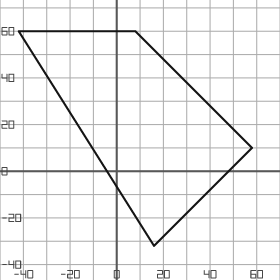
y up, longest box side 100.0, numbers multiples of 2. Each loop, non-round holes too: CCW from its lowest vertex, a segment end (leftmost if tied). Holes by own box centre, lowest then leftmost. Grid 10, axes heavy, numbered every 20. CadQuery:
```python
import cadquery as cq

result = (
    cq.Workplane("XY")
    .moveTo(16.0, -32.0)
    .lineTo(58.0, 10.0)
    .lineTo(8.0, 60.0)
    .lineTo(-42.0, 60.0)
    .close()
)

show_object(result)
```